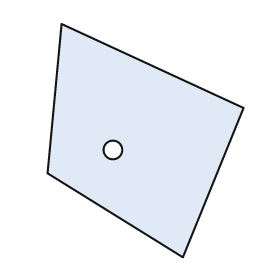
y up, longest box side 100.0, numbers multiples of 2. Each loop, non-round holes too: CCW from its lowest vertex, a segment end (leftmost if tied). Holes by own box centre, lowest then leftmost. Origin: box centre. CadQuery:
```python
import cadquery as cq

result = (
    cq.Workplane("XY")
    .moveTo(16.0, -50.0)
    .lineTo(42.0, 14.0)
    .lineTo(-36.0, 50.0)
    .lineTo(-42.0, -14.0)
    .close()
    .moveTo(-14.0, -4.0)
    .circle(4.0)
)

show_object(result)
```